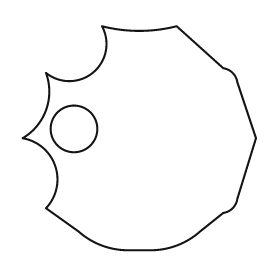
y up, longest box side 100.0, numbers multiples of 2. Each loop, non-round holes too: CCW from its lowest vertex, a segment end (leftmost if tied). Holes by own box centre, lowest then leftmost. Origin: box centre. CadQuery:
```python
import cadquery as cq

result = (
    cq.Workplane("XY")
    .moveTo(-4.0, -48.0)
    .lineTo(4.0, -48.0)
    .threePointArc((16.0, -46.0), (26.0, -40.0))
    .lineTo(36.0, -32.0)
    .threePointArc((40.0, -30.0), (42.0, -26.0))
    .lineTo(50.0, 0.0)
    .lineTo(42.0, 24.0)
    .threePointArc((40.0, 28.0), (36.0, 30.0))
    .lineTo(16.0, 48.0)
    .threePointArc((0.0, 46.0), (-16.0, 48.0))
    .threePointArc((-20.0, 28.0), (-40.0, 28.0))
    .threePointArc((-40.0, 12.0), (-50.0, 0.0))
    .threePointArc((-36.0, -12.0), (-40.0, -30.0))
    .lineTo(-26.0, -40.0)
    .threePointArc((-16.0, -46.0), (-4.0, -48.0))
    .close()
    .moveTo(-28.0, 4.0)
    .circle(10.0)
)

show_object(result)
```